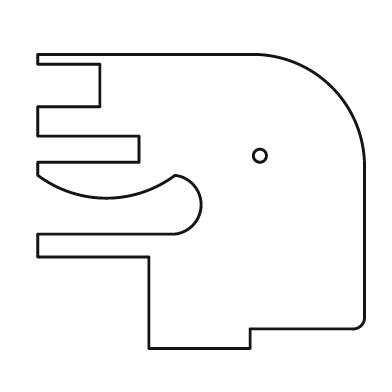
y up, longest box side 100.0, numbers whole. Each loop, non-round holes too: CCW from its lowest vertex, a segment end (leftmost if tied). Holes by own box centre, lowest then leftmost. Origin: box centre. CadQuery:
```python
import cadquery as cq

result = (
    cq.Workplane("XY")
    .moveTo(-16.0, -45.0)
    .lineTo(15.0, -45.0)
    .lineTo(15.0, -39.0)
    .lineTo(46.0, -39.0)
    .threePointArc((49.0, -38.0), (50.0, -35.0))
    .lineTo(50.0, 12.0)
    .threePointArc((40.0, 35.0), (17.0, 45.0))
    .lineTo(-50.0, 45.0)
    .lineTo(-50.0, 42.0)
    .lineTo(-31.0, 42.0)
    .lineTo(-31.0, 29.0)
    .lineTo(-50.0, 29.0)
    .lineTo(-50.0, 20.0)
    .lineTo(-19.0, 20.0)
    .lineTo(-19.0, 12.0)
    .lineTo(-50.0, 12.0)
    .lineTo(-50.0, 8.0)
    .threePointArc((-29.0, 1.0), (-8.0, 8.0))
    .threePointArc((0.0, -1.0), (-8.0, -10.0))
    .lineTo(-50.0, -10.0)
    .lineTo(-50.0, -17.0)
    .lineTo(-16.0, -17.0)
    .close()
    .moveTo(18.0, 14.0)
    .circle(2.0)
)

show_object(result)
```